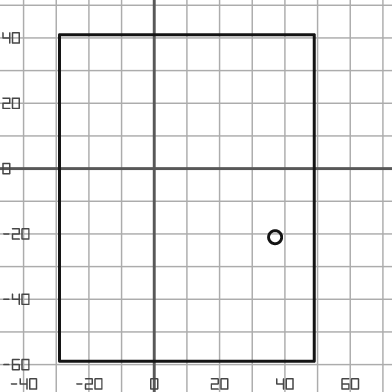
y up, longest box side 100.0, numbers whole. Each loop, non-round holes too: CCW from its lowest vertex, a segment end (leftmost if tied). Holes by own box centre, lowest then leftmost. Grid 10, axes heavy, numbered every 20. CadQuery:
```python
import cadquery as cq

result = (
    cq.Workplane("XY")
    .moveTo(-29.0, -59.0)
    .lineTo(49.0, -59.0)
    .lineTo(49.0, 41.0)
    .lineTo(-29.0, 41.0)
    .close()
    .moveTo(37.0, -21.0)
    .circle(2.0)
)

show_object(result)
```